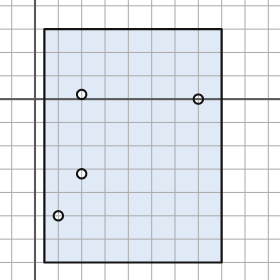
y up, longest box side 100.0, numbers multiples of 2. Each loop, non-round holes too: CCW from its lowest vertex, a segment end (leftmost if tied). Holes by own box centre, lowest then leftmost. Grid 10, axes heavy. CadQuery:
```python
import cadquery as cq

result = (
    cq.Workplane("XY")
    .moveTo(4.0, -70.0)
    .lineTo(80.0, -70.0)
    .lineTo(80.0, 30.0)
    .lineTo(4.0, 30.0)
    .close()
    .moveTo(10.0, -50.0)
    .circle(2.0)
    .moveTo(20.0, -32.0)
    .circle(2.0)
    .moveTo(70.0, 0.0)
    .circle(2.0)
    .moveTo(20.0, 2.0)
    .circle(2.0)
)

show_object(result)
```